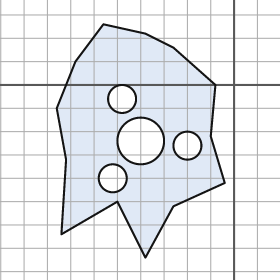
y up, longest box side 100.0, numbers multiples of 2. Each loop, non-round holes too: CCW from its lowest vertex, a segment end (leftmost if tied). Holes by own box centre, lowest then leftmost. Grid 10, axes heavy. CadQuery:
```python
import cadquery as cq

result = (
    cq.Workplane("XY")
    .moveTo(-38.0, -74.0)
    .lineTo(-26.0, -52.0)
    .lineTo(-4.0, -42.0)
    .lineTo(-10.0, -22.0)
    .lineTo(-8.0, 0.0)
    .lineTo(-26.0, 16.0)
    .lineTo(-38.0, 22.0)
    .lineTo(-56.0, 26.0)
    .lineTo(-68.0, 10.0)
    .lineTo(-76.0, -10.0)
    .lineTo(-72.0, -32.0)
    .lineTo(-74.0, -64.0)
    .lineTo(-50.0, -50.0)
    .close()
    .moveTo(-52.0, -40.0)
    .circle(6.0)
    .moveTo(-20.0, -26.0)
    .circle(6.0)
    .moveTo(-40.0, -24.0)
    .circle(10.0)
    .moveTo(-48.0, -6.0)
    .circle(6.0)
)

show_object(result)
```